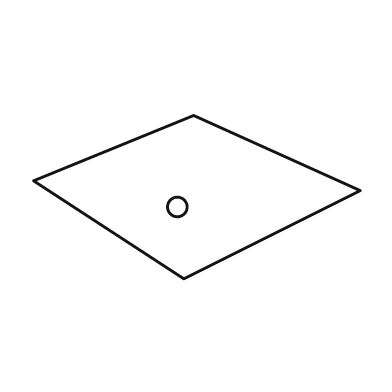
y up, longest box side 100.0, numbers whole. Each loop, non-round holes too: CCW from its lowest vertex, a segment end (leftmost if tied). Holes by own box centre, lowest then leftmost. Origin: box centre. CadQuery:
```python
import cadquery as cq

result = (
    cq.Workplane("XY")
    .moveTo(-4.0, -25.0)
    .lineTo(50.0, 2.0)
    .lineTo(-1.0, 25.0)
    .lineTo(-50.0, 5.0)
    .close()
    .moveTo(-6.0, -3.0)
    .circle(3.0)
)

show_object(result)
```